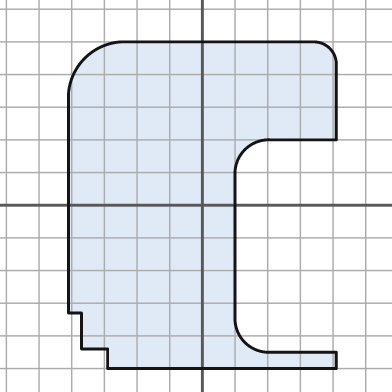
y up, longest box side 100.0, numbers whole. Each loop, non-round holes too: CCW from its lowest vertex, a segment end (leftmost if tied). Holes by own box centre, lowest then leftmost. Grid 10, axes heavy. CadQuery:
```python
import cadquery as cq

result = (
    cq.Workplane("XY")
    .moveTo(-29.0, -50.0)
    .lineTo(41.0, -50.0)
    .lineTo(41.0, -45.0)
    .lineTo(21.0, -45.0)
    .threePointArc((13.0, -42.0), (10.0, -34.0))
    .lineTo(10.0, 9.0)
    .threePointArc((13.0, 17.0), (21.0, 20.0))
    .lineTo(41.0, 20.0)
    .lineTo(41.0, 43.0)
    .threePointArc((39.0, 48.0), (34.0, 50.0))
    .lineTo(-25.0, 50.0)
    .threePointArc((-36.0, 45.0), (-41.0, 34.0))
    .lineTo(-41.0, -33.0)
    .lineTo(-37.0, -33.0)
    .lineTo(-37.0, -44.0)
    .lineTo(-29.0, -44.0)
    .close()
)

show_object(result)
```